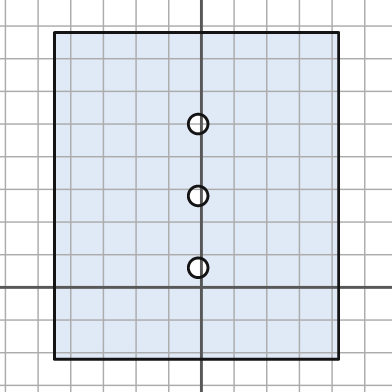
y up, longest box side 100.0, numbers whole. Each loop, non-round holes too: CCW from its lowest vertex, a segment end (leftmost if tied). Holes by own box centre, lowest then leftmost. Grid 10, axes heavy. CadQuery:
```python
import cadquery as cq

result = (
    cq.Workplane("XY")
    .moveTo(-45.0, -22.0)
    .lineTo(42.0, -22.0)
    .lineTo(42.0, 78.0)
    .lineTo(-45.0, 78.0)
    .close()
    .moveTo(-1.0, 6.0)
    .circle(3.0)
    .moveTo(-1.0, 28.0)
    .circle(3.0)
    .moveTo(-1.0, 50.0)
    .circle(3.0)
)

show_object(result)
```